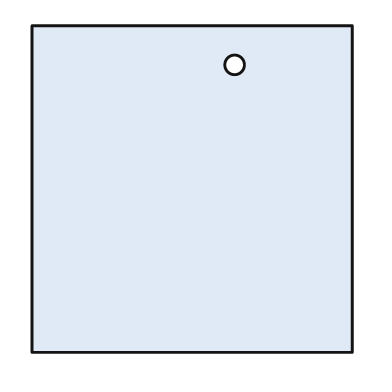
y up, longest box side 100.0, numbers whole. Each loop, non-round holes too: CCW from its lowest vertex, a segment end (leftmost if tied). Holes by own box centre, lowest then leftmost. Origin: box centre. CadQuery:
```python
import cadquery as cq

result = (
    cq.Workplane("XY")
    .moveTo(-49.0, -50.0)
    .lineTo(49.0, -50.0)
    .lineTo(49.0, 50.0)
    .lineTo(-49.0, 50.0)
    .close()
    .moveTo(13.0, 38.0)
    .circle(3.0)
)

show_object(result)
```